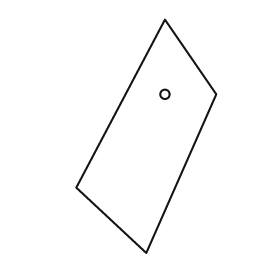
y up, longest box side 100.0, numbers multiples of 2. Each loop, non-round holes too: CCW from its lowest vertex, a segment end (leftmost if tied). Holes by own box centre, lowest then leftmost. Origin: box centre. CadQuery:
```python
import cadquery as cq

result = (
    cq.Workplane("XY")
    .moveTo(0.0, -50.0)
    .lineTo(30.0, 18.0)
    .lineTo(8.0, 50.0)
    .lineTo(-30.0, -22.0)
    .close()
    .moveTo(8.0, 18.0)
    .circle(2.0)
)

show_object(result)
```